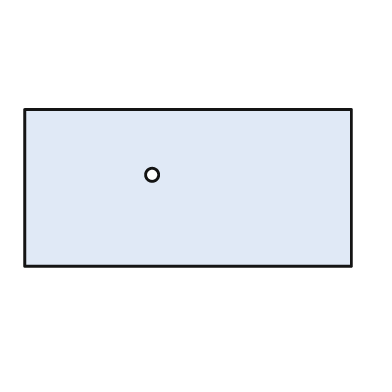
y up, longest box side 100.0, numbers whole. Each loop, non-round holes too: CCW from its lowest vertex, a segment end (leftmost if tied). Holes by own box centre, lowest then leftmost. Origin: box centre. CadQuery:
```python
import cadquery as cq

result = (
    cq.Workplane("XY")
    .moveTo(-50.0, -24.0)
    .lineTo(50.0, -24.0)
    .lineTo(50.0, 24.0)
    .lineTo(-50.0, 24.0)
    .close()
    .moveTo(-11.0, 4.0)
    .circle(2.0)
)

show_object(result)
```